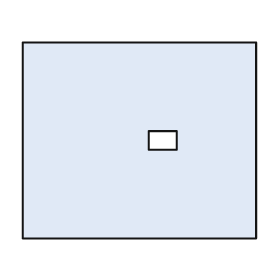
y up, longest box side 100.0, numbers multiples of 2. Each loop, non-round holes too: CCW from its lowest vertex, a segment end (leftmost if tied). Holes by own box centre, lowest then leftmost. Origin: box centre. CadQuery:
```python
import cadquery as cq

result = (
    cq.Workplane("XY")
    .moveTo(-50.0, -42.0)
    .lineTo(50.0, -42.0)
    .lineTo(50.0, 42.0)
    .lineTo(-50.0, 42.0)
    .close()
    .moveTo(4.0, -4.0)
    .lineTo(16.0, -4.0)
    .lineTo(16.0, 4.0)
    .lineTo(4.0, 4.0)
    .close()
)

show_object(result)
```